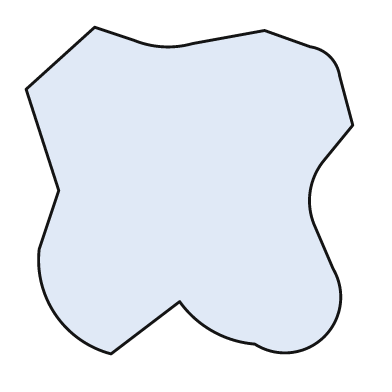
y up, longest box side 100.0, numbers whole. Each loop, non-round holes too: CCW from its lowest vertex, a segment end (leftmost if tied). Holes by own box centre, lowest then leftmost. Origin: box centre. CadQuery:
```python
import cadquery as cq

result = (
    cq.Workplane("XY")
    .moveTo(-24.0, -50.0)
    .lineTo(-3.0, -34.0)
    .threePointArc((7.0, -43.0), (20.0, -47.0))
    .threePointArc((41.0, -45.0), (44.0, -24.0))
    .lineTo(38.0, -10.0)
    .threePointArc((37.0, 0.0), (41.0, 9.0))
    .lineTo(50.0, 20.0)
    .lineTo(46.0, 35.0)
    .threePointArc((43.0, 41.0), (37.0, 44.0))
    .lineTo(23.0, 49.0)
    .lineTo(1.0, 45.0)
    .threePointArc((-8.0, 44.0), (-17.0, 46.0))
    .lineTo(-29.0, 50.0)
    .lineTo(-50.0, 31.0)
    .lineTo(-40.0, 0.0)
    .lineTo(-46.0, -18.0)
    .threePointArc((-41.0, -38.0), (-24.0, -50.0))
    .close()
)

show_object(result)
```